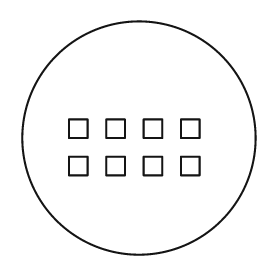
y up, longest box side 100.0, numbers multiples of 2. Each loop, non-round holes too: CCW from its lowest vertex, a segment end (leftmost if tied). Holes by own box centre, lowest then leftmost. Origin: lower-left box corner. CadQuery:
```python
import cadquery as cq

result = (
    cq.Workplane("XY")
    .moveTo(50.0, 50.0)
    .circle(50.0)
    .moveTo(20.0, 34.0)
    .lineTo(28.0, 34.0)
    .lineTo(28.0, 42.0)
    .lineTo(20.0, 42.0)
    .close()
    .moveTo(36.0, 34.0)
    .lineTo(44.0, 34.0)
    .lineTo(44.0, 42.0)
    .lineTo(36.0, 42.0)
    .close()
    .moveTo(52.0, 34.0)
    .lineTo(60.0, 34.0)
    .lineTo(60.0, 42.0)
    .lineTo(52.0, 42.0)
    .close()
    .moveTo(68.0, 34.0)
    .lineTo(76.0, 34.0)
    .lineTo(76.0, 42.0)
    .lineTo(68.0, 42.0)
    .close()
    .moveTo(20.0, 50.0)
    .lineTo(28.0, 50.0)
    .lineTo(28.0, 58.0)
    .lineTo(20.0, 58.0)
    .close()
    .moveTo(36.0, 50.0)
    .lineTo(44.0, 50.0)
    .lineTo(44.0, 58.0)
    .lineTo(36.0, 58.0)
    .close()
    .moveTo(52.0, 50.0)
    .lineTo(60.0, 50.0)
    .lineTo(60.0, 58.0)
    .lineTo(52.0, 58.0)
    .close()
    .moveTo(68.0, 50.0)
    .lineTo(76.0, 50.0)
    .lineTo(76.0, 58.0)
    .lineTo(68.0, 58.0)
    .close()
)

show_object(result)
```